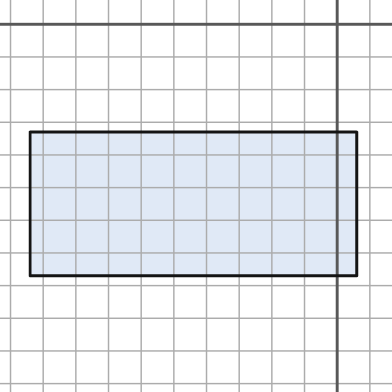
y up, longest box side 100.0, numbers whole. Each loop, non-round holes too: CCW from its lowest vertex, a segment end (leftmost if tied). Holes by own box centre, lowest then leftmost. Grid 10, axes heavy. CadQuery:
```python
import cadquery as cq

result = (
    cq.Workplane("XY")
    .moveTo(-94.0, -77.0)
    .lineTo(6.0, -77.0)
    .lineTo(6.0, -33.0)
    .lineTo(-94.0, -33.0)
    .close()
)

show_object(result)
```